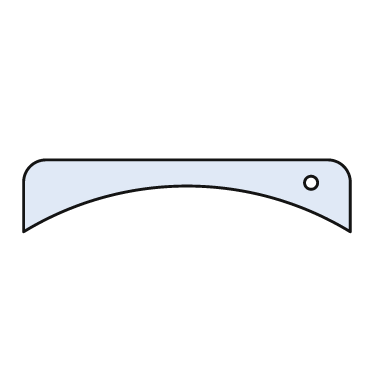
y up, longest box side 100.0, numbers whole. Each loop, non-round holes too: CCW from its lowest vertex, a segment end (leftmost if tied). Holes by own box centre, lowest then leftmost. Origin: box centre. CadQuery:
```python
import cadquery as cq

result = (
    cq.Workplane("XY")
    .moveTo(-50.0, -11.0)
    .threePointArc((0.0, 3.0), (50.0, -11.0))
    .lineTo(50.0, 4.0)
    .threePointArc((48.0, 9.0), (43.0, 11.0))
    .lineTo(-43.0, 11.0)
    .threePointArc((-48.0, 9.0), (-50.0, 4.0))
    .close()
    .moveTo(38.0, 4.0)
    .circle(2.0)
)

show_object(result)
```